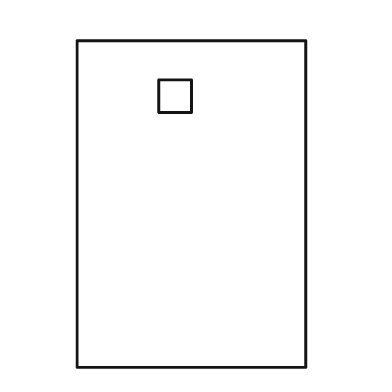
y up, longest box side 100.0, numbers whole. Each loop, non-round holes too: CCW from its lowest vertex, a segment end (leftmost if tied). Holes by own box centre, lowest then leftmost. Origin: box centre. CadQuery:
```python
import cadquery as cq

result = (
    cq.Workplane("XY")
    .moveTo(-35.0, -50.0)
    .lineTo(35.0, -50.0)
    .lineTo(35.0, 50.0)
    .lineTo(-35.0, 50.0)
    .close()
    .moveTo(-10.0, 28.0)
    .lineTo(0.0, 28.0)
    .lineTo(0.0, 38.0)
    .lineTo(-10.0, 38.0)
    .close()
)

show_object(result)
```